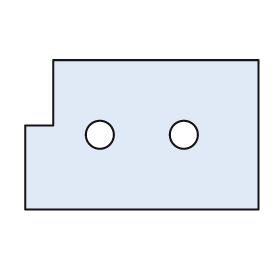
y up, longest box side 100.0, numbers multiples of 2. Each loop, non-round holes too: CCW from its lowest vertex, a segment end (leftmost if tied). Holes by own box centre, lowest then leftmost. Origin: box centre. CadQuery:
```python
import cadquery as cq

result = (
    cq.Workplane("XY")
    .moveTo(-50.0, -32.0)
    .lineTo(50.0, -32.0)
    .lineTo(50.0, 32.0)
    .lineTo(-38.0, 32.0)
    .lineTo(-38.0, 4.0)
    .lineTo(-50.0, 4.0)
    .close()
    .moveTo(-18.0, 0.0)
    .circle(6.0)
    .moveTo(18.0, 0.0)
    .circle(6.0)
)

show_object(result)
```